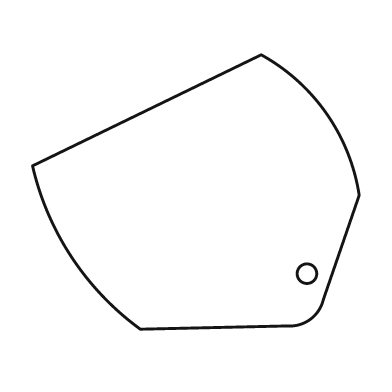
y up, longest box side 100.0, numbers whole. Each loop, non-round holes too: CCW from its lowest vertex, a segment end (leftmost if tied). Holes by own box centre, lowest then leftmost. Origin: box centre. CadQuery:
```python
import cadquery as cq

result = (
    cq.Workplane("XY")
    .moveTo(-17.0, -42.0)
    .lineTo(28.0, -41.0)
    .threePointArc((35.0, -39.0), (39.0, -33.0))
    .lineTo(50.0, -1.0)
    .threePointArc((40.0, 24.0), (20.0, 42.0))
    .lineTo(-50.0, 8.0)
    .threePointArc((-38.0, -20.0), (-17.0, -42.0))
    .close()
    .moveTo(34.0, -25.0)
    .circle(3.0)
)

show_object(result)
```